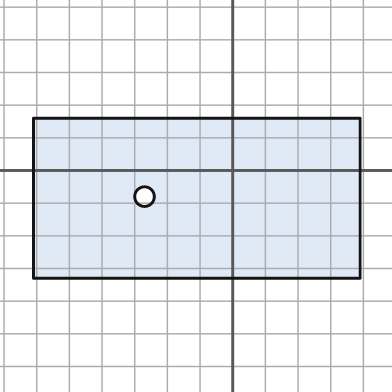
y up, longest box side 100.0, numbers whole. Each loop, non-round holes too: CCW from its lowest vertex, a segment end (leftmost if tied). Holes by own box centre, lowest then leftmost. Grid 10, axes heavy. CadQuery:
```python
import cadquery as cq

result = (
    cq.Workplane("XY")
    .moveTo(-61.0, -33.0)
    .lineTo(39.0, -33.0)
    .lineTo(39.0, 16.0)
    .lineTo(-61.0, 16.0)
    .close()
    .moveTo(-27.0, -8.0)
    .circle(3.0)
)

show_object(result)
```